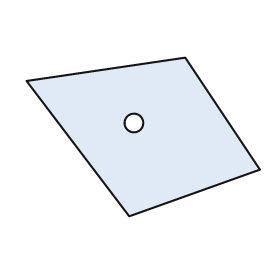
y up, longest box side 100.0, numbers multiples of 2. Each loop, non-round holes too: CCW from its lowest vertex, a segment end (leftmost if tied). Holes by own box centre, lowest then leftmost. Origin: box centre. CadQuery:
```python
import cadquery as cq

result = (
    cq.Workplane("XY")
    .moveTo(-6.0, -34.0)
    .lineTo(50.0, -14.0)
    .lineTo(18.0, 34.0)
    .lineTo(-50.0, 24.0)
    .close()
    .moveTo(-4.0, 6.0)
    .circle(4.0)
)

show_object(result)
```